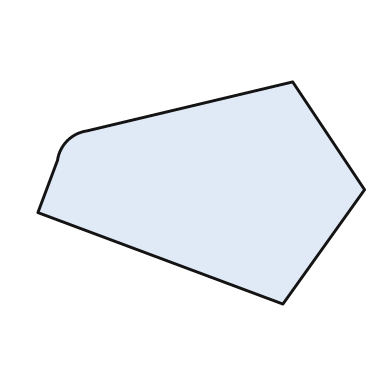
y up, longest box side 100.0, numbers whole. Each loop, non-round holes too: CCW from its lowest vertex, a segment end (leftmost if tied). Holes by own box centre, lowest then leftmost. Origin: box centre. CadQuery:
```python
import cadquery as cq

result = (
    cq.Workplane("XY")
    .moveTo(25.0, -34.0)
    .lineTo(50.0, 1.0)
    .lineTo(28.0, 34.0)
    .lineTo(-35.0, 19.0)
    .threePointArc((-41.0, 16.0), (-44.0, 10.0))
    .lineTo(-50.0, -6.0)
    .close()
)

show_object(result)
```